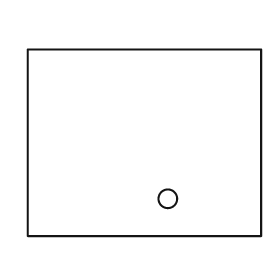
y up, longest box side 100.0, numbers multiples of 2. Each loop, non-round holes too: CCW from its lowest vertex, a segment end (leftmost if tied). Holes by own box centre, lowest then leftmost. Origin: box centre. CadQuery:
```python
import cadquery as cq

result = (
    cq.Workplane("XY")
    .moveTo(-50.0, -40.0)
    .lineTo(50.0, -40.0)
    .lineTo(50.0, 40.0)
    .lineTo(-50.0, 40.0)
    .close()
    .moveTo(10.0, -24.0)
    .circle(4.0)
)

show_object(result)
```